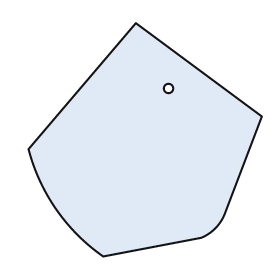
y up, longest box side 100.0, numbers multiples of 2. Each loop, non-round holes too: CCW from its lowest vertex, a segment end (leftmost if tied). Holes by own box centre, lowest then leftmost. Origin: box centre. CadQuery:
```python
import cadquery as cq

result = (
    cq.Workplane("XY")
    .moveTo(-18.0, -50.0)
    .lineTo(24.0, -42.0)
    .threePointArc((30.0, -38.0), (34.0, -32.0))
    .lineTo(50.0, 10.0)
    .lineTo(-4.0, 50.0)
    .lineTo(-50.0, -4.0)
    .threePointArc((-38.0, -30.0), (-18.0, -50.0))
    .close()
    .moveTo(10.0, 22.0)
    .circle(2.0)
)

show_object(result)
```